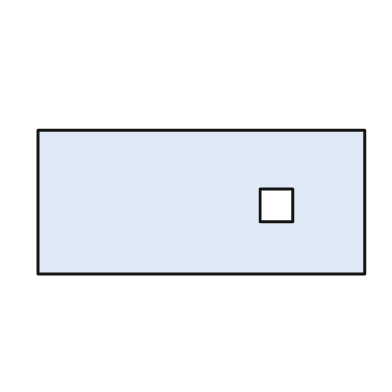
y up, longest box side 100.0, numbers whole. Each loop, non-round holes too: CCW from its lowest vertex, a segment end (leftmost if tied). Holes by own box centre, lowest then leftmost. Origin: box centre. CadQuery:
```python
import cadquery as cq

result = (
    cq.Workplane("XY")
    .moveTo(-50.0, -22.0)
    .lineTo(50.0, -22.0)
    .lineTo(50.0, 22.0)
    .lineTo(-50.0, 22.0)
    .close()
    .moveTo(18.0, -6.0)
    .lineTo(28.0, -6.0)
    .lineTo(28.0, 4.0)
    .lineTo(18.0, 4.0)
    .close()
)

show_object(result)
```